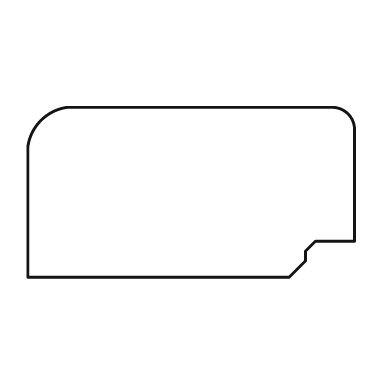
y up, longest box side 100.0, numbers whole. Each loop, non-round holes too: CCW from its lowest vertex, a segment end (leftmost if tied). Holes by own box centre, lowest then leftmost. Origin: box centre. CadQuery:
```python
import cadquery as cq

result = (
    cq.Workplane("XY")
    .moveTo(-50.0, -26.0)
    .lineTo(30.0, -26.0)
    .lineTo(35.0, -21.0)
    .lineTo(35.0, -18.0)
    .lineTo(38.0, -15.0)
    .lineTo(50.0, -15.0)
    .lineTo(50.0, 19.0)
    .threePointArc((48.0, 24.0), (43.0, 26.0))
    .lineTo(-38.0, 26.0)
    .threePointArc((-46.0, 22.0), (-50.0, 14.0))
    .close()
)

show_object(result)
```